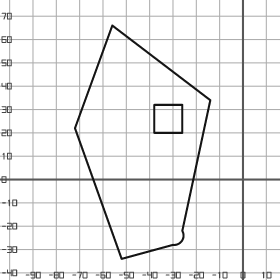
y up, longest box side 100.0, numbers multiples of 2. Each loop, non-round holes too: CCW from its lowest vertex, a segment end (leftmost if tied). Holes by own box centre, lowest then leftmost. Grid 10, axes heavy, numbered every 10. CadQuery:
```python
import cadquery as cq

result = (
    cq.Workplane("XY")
    .moveTo(-52.0, -34.0)
    .lineTo(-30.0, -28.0)
    .threePointArc((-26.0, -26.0), (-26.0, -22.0))
    .lineTo(-14.0, 34.0)
    .lineTo(-56.0, 66.0)
    .lineTo(-72.0, 22.0)
    .close()
    .moveTo(-38.0, 20.0)
    .lineTo(-26.0, 20.0)
    .lineTo(-26.0, 32.0)
    .lineTo(-38.0, 32.0)
    .close()
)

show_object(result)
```